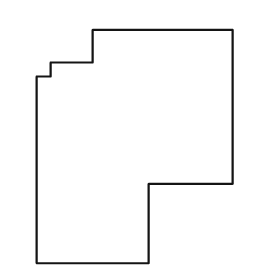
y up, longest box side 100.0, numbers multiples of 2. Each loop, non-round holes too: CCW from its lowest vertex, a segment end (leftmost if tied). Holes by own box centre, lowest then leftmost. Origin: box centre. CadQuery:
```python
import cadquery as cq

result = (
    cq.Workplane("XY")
    .moveTo(-42.0, -50.0)
    .lineTo(6.0, -50.0)
    .lineTo(6.0, -16.0)
    .lineTo(42.0, -16.0)
    .lineTo(42.0, 50.0)
    .lineTo(-18.0, 50.0)
    .lineTo(-18.0, 36.0)
    .lineTo(-36.0, 36.0)
    .lineTo(-36.0, 30.0)
    .lineTo(-42.0, 30.0)
    .close()
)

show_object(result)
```